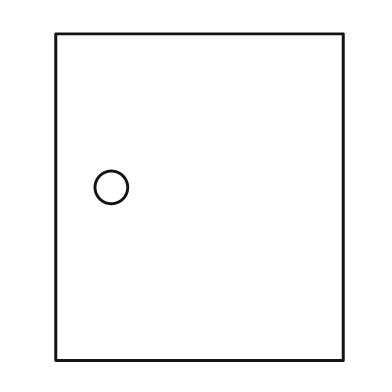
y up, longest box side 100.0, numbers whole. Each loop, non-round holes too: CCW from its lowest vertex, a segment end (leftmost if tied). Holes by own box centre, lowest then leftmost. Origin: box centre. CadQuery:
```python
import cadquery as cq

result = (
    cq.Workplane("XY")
    .moveTo(-44.0, -50.0)
    .lineTo(44.0, -50.0)
    .lineTo(44.0, 50.0)
    .lineTo(-44.0, 50.0)
    .close()
    .moveTo(-27.0, 3.0)
    .circle(5.0)
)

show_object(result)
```